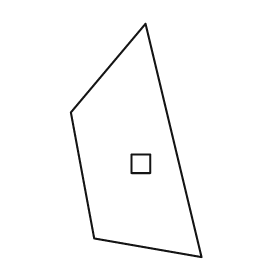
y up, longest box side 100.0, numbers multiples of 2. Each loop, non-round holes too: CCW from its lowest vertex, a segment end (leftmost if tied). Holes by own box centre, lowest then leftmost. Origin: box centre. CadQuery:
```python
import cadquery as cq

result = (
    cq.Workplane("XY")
    .moveTo(28.0, -50.0)
    .lineTo(4.0, 50.0)
    .lineTo(-28.0, 12.0)
    .lineTo(-18.0, -42.0)
    .close()
    .moveTo(-2.0, -14.0)
    .lineTo(6.0, -14.0)
    .lineTo(6.0, -6.0)
    .lineTo(-2.0, -6.0)
    .close()
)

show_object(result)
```